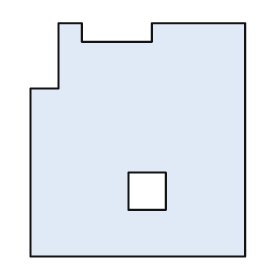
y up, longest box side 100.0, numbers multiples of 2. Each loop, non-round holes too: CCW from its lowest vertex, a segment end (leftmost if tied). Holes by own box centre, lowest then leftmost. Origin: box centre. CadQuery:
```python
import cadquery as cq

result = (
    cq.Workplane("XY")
    .moveTo(-46.0, -50.0)
    .lineTo(46.0, -50.0)
    .lineTo(46.0, 50.0)
    .lineTo(6.0, 50.0)
    .lineTo(6.0, 42.0)
    .lineTo(-24.0, 42.0)
    .lineTo(-24.0, 50.0)
    .lineTo(-34.0, 50.0)
    .lineTo(-34.0, 22.0)
    .lineTo(-46.0, 22.0)
    .close()
    .moveTo(-4.0, -30.0)
    .lineTo(12.0, -30.0)
    .lineTo(12.0, -14.0)
    .lineTo(-4.0, -14.0)
    .close()
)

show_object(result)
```